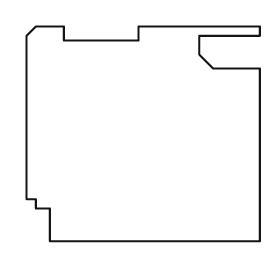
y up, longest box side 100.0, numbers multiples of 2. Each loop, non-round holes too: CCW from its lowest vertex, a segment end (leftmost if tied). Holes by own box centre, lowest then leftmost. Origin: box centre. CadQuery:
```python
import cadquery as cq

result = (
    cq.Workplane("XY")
    .moveTo(-40.0, -46.0)
    .lineTo(50.0, -46.0)
    .lineTo(50.0, 28.0)
    .lineTo(30.0, 28.0)
    .lineTo(24.0, 34.0)
    .lineTo(24.0, 42.0)
    .lineTo(50.0, 42.0)
    .lineTo(50.0, 46.0)
    .lineTo(-2.0, 46.0)
    .lineTo(-2.0, 40.0)
    .lineTo(-34.0, 40.0)
    .lineTo(-34.0, 46.0)
    .lineTo(-46.0, 46.0)
    .lineTo(-50.0, 42.0)
    .lineTo(-50.0, -28.0)
    .lineTo(-46.0, -28.0)
    .lineTo(-46.0, -32.0)
    .lineTo(-40.0, -32.0)
    .close()
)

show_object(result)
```